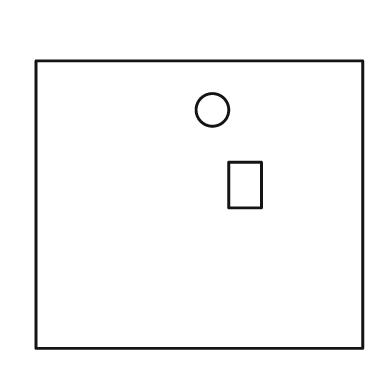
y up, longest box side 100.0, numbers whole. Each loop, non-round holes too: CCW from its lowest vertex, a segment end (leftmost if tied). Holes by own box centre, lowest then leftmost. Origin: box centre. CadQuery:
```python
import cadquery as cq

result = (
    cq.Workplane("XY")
    .moveTo(-50.0, -44.0)
    .lineTo(50.0, -44.0)
    .lineTo(50.0, 44.0)
    .lineTo(-50.0, 44.0)
    .close()
    .moveTo(9.0, -1.0)
    .lineTo(19.0, -1.0)
    .lineTo(19.0, 13.0)
    .lineTo(9.0, 13.0)
    .close()
    .moveTo(4.0, 29.0)
    .circle(5.0)
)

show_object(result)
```